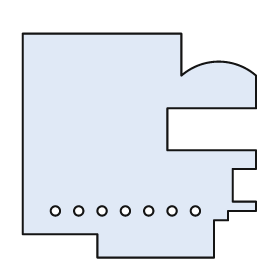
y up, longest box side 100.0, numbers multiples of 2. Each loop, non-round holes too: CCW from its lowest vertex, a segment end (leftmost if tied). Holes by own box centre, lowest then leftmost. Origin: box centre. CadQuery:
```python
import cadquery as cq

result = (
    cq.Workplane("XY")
    .moveTo(-18.0, -48.0)
    .lineTo(32.0, -48.0)
    .lineTo(32.0, -32.0)
    .lineTo(38.0, -32.0)
    .lineTo(38.0, -28.0)
    .lineTo(50.0, -28.0)
    .lineTo(50.0, -24.0)
    .lineTo(40.0, -24.0)
    .lineTo(40.0, -10.0)
    .lineTo(50.0, -10.0)
    .lineTo(50.0, -2.0)
    .lineTo(12.0, -2.0)
    .lineTo(12.0, 16.0)
    .lineTo(50.0, 16.0)
    .lineTo(50.0, 30.0)
    .threePointArc((34.0, 36.0), (18.0, 30.0))
    .lineTo(18.0, 48.0)
    .lineTo(-50.0, 48.0)
    .lineTo(-50.0, -38.0)
    .lineTo(-18.0, -38.0)
    .close()
    .moveTo(-36.0, -28.0)
    .circle(2.0)
    .moveTo(-26.0, -28.0)
    .circle(2.0)
    .moveTo(-16.0, -28.0)
    .circle(2.0)
    .moveTo(-6.0, -28.0)
    .circle(2.0)
    .moveTo(4.0, -28.0)
    .circle(2.0)
    .moveTo(14.0, -28.0)
    .circle(2.0)
    .moveTo(24.0, -28.0)
    .circle(2.0)
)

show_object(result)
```